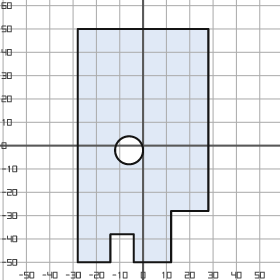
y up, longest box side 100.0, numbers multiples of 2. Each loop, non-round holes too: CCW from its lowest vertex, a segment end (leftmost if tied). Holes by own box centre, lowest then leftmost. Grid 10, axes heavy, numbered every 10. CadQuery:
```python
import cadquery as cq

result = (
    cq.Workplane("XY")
    .moveTo(-28.0, -50.0)
    .lineTo(-14.0, -50.0)
    .lineTo(-14.0, -38.0)
    .lineTo(-4.0, -38.0)
    .lineTo(-4.0, -50.0)
    .lineTo(12.0, -50.0)
    .lineTo(12.0, -28.0)
    .lineTo(28.0, -28.0)
    .lineTo(28.0, 50.0)
    .lineTo(-28.0, 50.0)
    .close()
    .moveTo(-6.0, -2.0)
    .circle(6.0)
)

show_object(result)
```